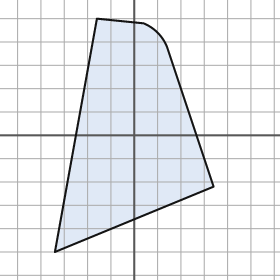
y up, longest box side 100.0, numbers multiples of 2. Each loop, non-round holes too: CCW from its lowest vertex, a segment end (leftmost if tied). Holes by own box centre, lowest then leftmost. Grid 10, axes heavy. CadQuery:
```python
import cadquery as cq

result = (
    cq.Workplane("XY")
    .moveTo(-34.0, -50.0)
    .lineTo(34.0, -22.0)
    .lineTo(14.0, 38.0)
    .threePointArc((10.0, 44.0), (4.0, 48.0))
    .lineTo(-16.0, 50.0)
    .close()
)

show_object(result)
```